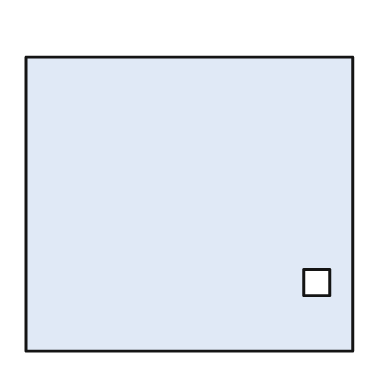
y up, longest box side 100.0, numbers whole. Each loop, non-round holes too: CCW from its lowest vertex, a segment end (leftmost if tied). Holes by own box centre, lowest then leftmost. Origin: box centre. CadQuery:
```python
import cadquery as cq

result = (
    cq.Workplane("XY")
    .moveTo(-50.0, -45.0)
    .lineTo(50.0, -45.0)
    .lineTo(50.0, 45.0)
    .lineTo(-50.0, 45.0)
    .close()
    .moveTo(35.0, -28.0)
    .lineTo(43.0, -28.0)
    .lineTo(43.0, -20.0)
    .lineTo(35.0, -20.0)
    .close()
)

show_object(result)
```